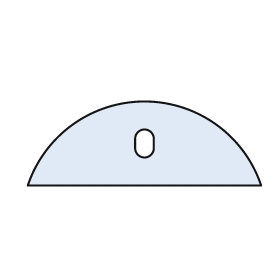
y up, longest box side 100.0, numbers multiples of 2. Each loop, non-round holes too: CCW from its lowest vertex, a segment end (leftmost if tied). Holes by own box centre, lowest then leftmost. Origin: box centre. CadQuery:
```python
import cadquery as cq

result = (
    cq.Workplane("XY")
    .moveTo(-50.0, -18.0)
    .lineTo(50.0, -18.0)
    .threePointArc((0.0, 18.0), (-50.0, -18.0))
    .close()
    .moveTo(-4.0, -2.0)
    .threePointArc((0.0, -6.0), (4.0, -2.0))
    .lineTo(4.0, 2.0)
    .threePointArc((0.0, 6.0), (-4.0, 2.0))
    .close()
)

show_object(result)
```